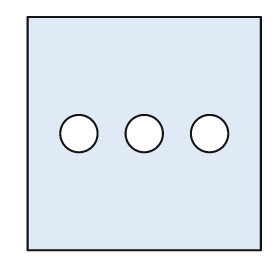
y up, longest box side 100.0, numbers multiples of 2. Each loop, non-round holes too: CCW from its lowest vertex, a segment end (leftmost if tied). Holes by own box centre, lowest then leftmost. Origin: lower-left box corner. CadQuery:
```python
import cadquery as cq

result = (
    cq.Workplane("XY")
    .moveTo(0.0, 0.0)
    .lineTo(100.0, 0.0)
    .lineTo(100.0, 100.0)
    .lineTo(0.0, 100.0)
    .close()
    .moveTo(22.0, 50.0)
    .circle(8.0)
    .moveTo(50.0, 50.0)
    .circle(8.0)
    .moveTo(78.0, 50.0)
    .circle(8.0)
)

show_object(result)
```